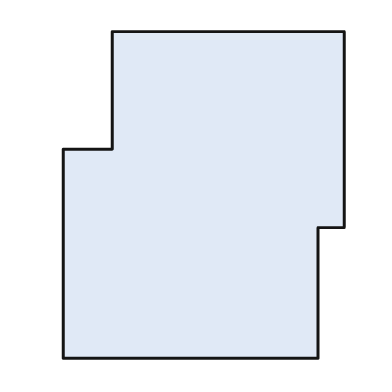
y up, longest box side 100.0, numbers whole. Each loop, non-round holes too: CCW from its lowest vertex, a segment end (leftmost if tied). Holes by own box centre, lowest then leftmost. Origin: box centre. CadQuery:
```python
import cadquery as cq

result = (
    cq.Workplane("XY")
    .moveTo(-43.0, -50.0)
    .lineTo(35.0, -50.0)
    .lineTo(35.0, -10.0)
    .lineTo(43.0, -10.0)
    .lineTo(43.0, 50.0)
    .lineTo(-28.0, 50.0)
    .lineTo(-28.0, 14.0)
    .lineTo(-43.0, 14.0)
    .close()
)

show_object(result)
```